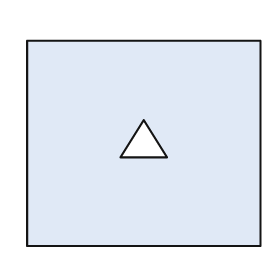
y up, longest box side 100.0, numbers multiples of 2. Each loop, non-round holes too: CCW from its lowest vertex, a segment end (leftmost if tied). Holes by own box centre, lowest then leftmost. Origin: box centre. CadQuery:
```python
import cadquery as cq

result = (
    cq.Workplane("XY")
    .moveTo(-50.0, -44.0)
    .lineTo(50.0, -44.0)
    .lineTo(50.0, 44.0)
    .lineTo(-50.0, 44.0)
    .close()
    .moveTo(-10.0, -6.0)
    .lineTo(10.0, -6.0)
    .lineTo(0.0, 10.0)
    .close()
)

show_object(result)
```